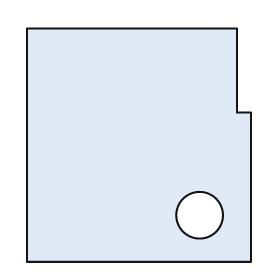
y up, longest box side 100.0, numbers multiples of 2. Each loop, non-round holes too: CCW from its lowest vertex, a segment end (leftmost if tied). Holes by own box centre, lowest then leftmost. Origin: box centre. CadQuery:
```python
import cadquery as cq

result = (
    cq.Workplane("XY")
    .moveTo(-48.0, -50.0)
    .lineTo(48.0, -50.0)
    .lineTo(48.0, 14.0)
    .lineTo(42.0, 14.0)
    .lineTo(42.0, 50.0)
    .lineTo(-48.0, 50.0)
    .close()
    .moveTo(26.0, -30.0)
    .circle(10.0)
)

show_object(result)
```